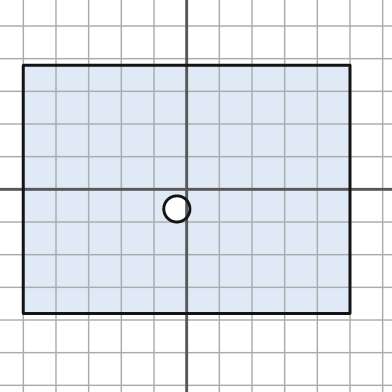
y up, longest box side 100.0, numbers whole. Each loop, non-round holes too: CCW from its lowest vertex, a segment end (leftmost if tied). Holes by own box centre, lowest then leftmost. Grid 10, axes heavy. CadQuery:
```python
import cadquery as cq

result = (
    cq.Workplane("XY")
    .moveTo(-50.0, -38.0)
    .lineTo(50.0, -38.0)
    .lineTo(50.0, 38.0)
    .lineTo(-50.0, 38.0)
    .close()
    .moveTo(-3.0, -6.0)
    .circle(4.0)
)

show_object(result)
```